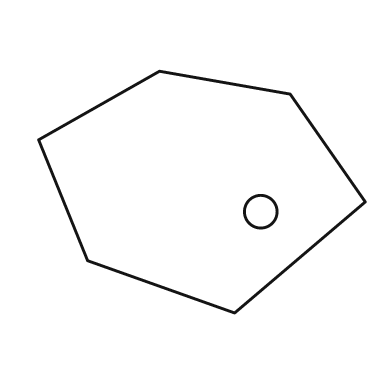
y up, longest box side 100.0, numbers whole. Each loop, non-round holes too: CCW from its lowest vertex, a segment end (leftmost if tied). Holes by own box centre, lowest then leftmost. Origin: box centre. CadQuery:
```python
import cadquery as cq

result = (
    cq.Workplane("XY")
    .moveTo(10.0, -37.0)
    .lineTo(50.0, -3.0)
    .lineTo(27.0, 30.0)
    .lineTo(-13.0, 37.0)
    .lineTo(-50.0, 16.0)
    .lineTo(-35.0, -21.0)
    .close()
    .moveTo(18.0, -6.0)
    .circle(5.0)
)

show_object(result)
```